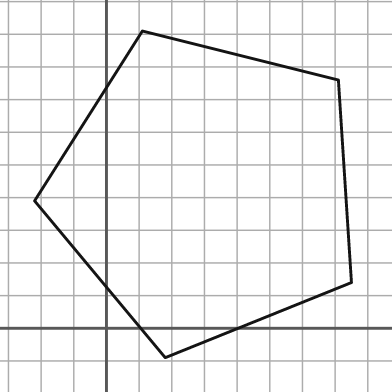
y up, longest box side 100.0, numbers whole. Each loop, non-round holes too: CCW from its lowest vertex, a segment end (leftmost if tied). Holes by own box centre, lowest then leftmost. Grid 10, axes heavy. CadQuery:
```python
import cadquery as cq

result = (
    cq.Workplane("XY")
    .moveTo(18.0, -9.0)
    .lineTo(75.0, 14.0)
    .lineTo(71.0, 76.0)
    .lineTo(11.0, 91.0)
    .lineTo(-22.0, 39.0)
    .close()
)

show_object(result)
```